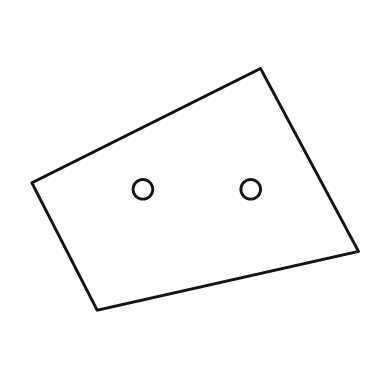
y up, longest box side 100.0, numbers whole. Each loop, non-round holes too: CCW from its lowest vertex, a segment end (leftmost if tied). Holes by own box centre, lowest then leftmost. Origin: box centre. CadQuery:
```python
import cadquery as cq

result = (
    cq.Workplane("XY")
    .moveTo(-30.0, -37.0)
    .lineTo(50.0, -19.0)
    .lineTo(20.0, 37.0)
    .lineTo(-50.0, 2.0)
    .close()
    .moveTo(-16.0, 0.0)
    .circle(3.0)
    .moveTo(17.0, 0.0)
    .circle(3.0)
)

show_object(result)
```